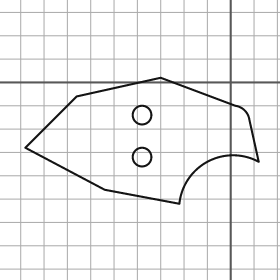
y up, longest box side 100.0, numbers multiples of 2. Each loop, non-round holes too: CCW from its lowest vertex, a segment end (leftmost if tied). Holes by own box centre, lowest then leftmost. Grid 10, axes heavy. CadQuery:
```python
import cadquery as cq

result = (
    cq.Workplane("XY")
    .moveTo(-22.0, -52.0)
    .threePointArc((-10.0, -34.0), (12.0, -34.0))
    .lineTo(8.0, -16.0)
    .threePointArc((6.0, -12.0), (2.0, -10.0))
    .lineTo(-30.0, 2.0)
    .lineTo(-66.0, -6.0)
    .lineTo(-88.0, -28.0)
    .lineTo(-54.0, -46.0)
    .close()
    .moveTo(-38.0, -32.0)
    .circle(4.0)
    .moveTo(-38.0, -14.0)
    .circle(4.0)
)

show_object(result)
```